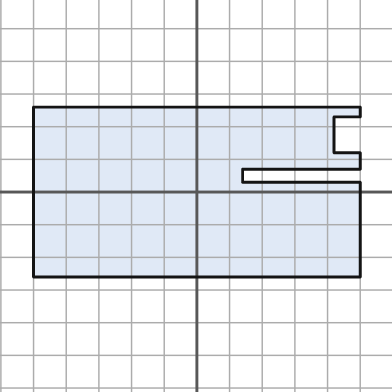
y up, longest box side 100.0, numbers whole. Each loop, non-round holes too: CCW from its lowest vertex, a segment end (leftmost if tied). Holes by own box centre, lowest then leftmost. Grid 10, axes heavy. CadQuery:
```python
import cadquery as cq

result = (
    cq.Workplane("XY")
    .moveTo(-50.0, -26.0)
    .lineTo(50.0, -26.0)
    .lineTo(50.0, 3.0)
    .lineTo(14.0, 3.0)
    .lineTo(14.0, 7.0)
    .lineTo(50.0, 7.0)
    .lineTo(50.0, 12.0)
    .lineTo(42.0, 12.0)
    .lineTo(42.0, 23.0)
    .lineTo(50.0, 23.0)
    .lineTo(50.0, 26.0)
    .lineTo(-50.0, 26.0)
    .close()
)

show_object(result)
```